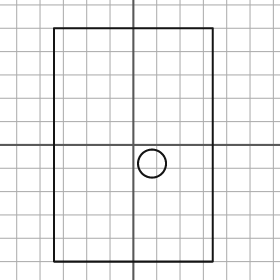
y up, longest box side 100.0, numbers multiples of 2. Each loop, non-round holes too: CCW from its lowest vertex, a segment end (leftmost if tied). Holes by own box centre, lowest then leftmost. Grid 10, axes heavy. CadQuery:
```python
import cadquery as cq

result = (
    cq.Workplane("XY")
    .moveTo(-34.0, -50.0)
    .lineTo(34.0, -50.0)
    .lineTo(34.0, 50.0)
    .lineTo(-34.0, 50.0)
    .close()
    .moveTo(8.0, -8.0)
    .circle(6.0)
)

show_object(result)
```